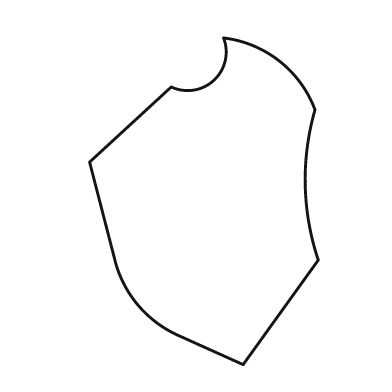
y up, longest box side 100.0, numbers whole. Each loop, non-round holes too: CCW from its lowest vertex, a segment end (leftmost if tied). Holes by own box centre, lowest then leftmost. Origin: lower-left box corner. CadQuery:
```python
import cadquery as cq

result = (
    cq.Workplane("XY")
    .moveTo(47.0, 0.0)
    .lineTo(70.0, 32.0)
    .threePointArc((66.0, 55.0), (69.0, 78.0))
    .threePointArc((58.0, 93.0), (41.0, 100.0))
    .threePointArc((38.0, 87.0), (25.0, 85.0))
    .lineTo(0.0, 62.0)
    .lineTo(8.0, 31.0)
    .threePointArc((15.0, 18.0), (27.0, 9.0))
    .close()
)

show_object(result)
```